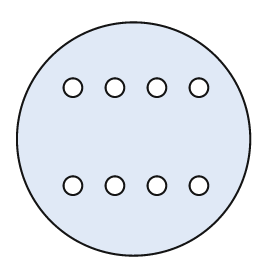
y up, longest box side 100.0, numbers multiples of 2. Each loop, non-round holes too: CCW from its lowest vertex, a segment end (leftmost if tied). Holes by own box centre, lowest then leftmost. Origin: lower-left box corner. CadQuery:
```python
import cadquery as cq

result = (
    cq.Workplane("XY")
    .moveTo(50.0, 50.0)
    .circle(50.0)
    .moveTo(24.0, 30.0)
    .circle(4.0)
    .moveTo(42.0, 30.0)
    .circle(4.0)
    .moveTo(60.0, 30.0)
    .circle(4.0)
    .moveTo(78.0, 30.0)
    .circle(4.0)
    .moveTo(24.0, 72.0)
    .circle(4.0)
    .moveTo(42.0, 72.0)
    .circle(4.0)
    .moveTo(60.0, 72.0)
    .circle(4.0)
    .moveTo(78.0, 72.0)
    .circle(4.0)
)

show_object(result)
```